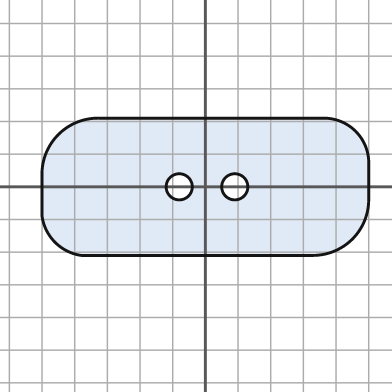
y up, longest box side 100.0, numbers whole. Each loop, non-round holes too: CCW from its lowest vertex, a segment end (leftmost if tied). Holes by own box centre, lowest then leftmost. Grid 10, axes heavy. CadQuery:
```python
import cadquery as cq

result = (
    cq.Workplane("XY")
    .moveTo(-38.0, -21.0)
    .lineTo(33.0, -21.0)
    .threePointArc((45.0, -16.0), (50.0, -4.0))
    .lineTo(50.0, 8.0)
    .threePointArc((46.0, 17.0), (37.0, 21.0))
    .lineTo(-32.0, 21.0)
    .threePointArc((-45.0, 16.0), (-50.0, 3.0))
    .lineTo(-50.0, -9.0)
    .threePointArc((-46.0, -17.0), (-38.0, -21.0))
    .close()
    .moveTo(-8.0, 0.0)
    .circle(4.0)
    .moveTo(9.0, 0.0)
    .circle(4.0)
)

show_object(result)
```